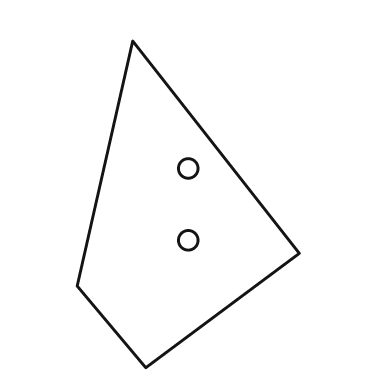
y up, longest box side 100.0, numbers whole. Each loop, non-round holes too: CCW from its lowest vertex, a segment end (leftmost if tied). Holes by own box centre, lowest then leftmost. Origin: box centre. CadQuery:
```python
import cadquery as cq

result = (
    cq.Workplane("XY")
    .moveTo(-13.0, -50.0)
    .lineTo(34.0, -15.0)
    .lineTo(-17.0, 50.0)
    .lineTo(-34.0, -25.0)
    .close()
    .moveTo(0.0, -11.0)
    .circle(3.0)
    .moveTo(0.0, 11.0)
    .circle(3.0)
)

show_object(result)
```